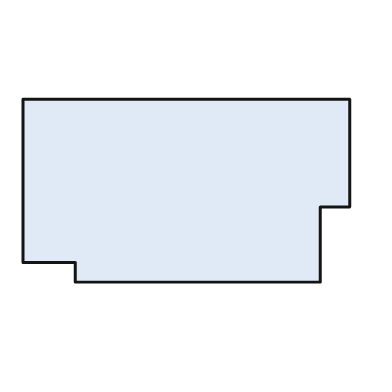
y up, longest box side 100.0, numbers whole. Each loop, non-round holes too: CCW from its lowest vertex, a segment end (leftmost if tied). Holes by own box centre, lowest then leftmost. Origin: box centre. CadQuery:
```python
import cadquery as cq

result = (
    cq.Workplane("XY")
    .moveTo(-34.0, -28.0)
    .lineTo(41.0, -28.0)
    .lineTo(41.0, -5.0)
    .lineTo(50.0, -5.0)
    .lineTo(50.0, 28.0)
    .lineTo(-50.0, 28.0)
    .lineTo(-50.0, -22.0)
    .lineTo(-34.0, -22.0)
    .close()
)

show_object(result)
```